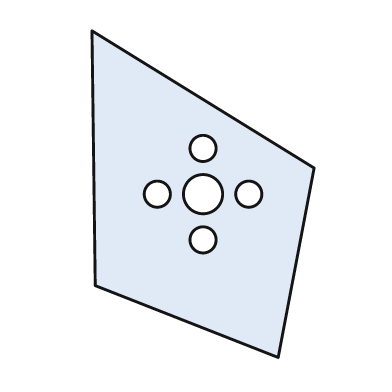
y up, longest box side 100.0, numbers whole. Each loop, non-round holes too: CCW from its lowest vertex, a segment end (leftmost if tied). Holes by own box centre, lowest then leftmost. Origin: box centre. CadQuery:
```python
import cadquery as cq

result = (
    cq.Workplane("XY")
    .moveTo(23.0, -50.0)
    .lineTo(34.0, 8.0)
    .lineTo(-34.0, 50.0)
    .lineTo(-33.0, -28.0)
    .close()
    .moveTo(0.0, -14.0)
    .circle(4.0)
    .moveTo(-14.0, 0.0)
    .circle(4.0)
    .moveTo(0.0, 0.0)
    .circle(6.0)
    .moveTo(14.0, 0.0)
    .circle(4.0)
    .moveTo(0.0, 14.0)
    .circle(4.0)
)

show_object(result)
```